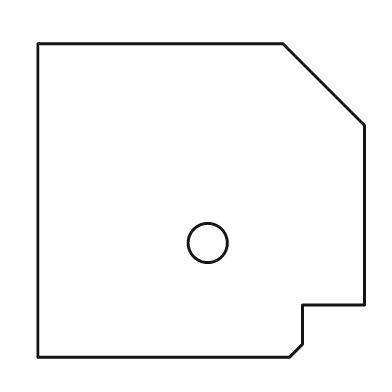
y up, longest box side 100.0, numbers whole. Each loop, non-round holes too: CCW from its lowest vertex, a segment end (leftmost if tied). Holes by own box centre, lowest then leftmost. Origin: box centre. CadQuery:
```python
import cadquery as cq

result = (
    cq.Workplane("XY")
    .moveTo(-50.0, -48.0)
    .lineTo(27.0, -48.0)
    .lineTo(31.0, -44.0)
    .lineTo(31.0, -32.0)
    .lineTo(50.0, -32.0)
    .lineTo(50.0, 23.0)
    .lineTo(25.0, 48.0)
    .lineTo(-50.0, 48.0)
    .close()
    .moveTo(2.0, -13.0)
    .circle(6.0)
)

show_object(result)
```